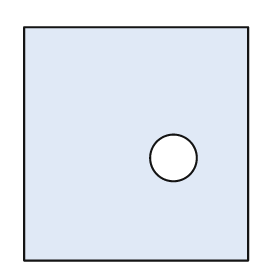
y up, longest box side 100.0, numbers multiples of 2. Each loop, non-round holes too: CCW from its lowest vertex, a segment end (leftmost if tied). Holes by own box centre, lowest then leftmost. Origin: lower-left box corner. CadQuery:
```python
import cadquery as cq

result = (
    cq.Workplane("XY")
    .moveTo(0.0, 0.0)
    .lineTo(96.0, 0.0)
    .lineTo(96.0, 100.0)
    .lineTo(0.0, 100.0)
    .close()
    .moveTo(64.0, 44.0)
    .circle(10.0)
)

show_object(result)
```